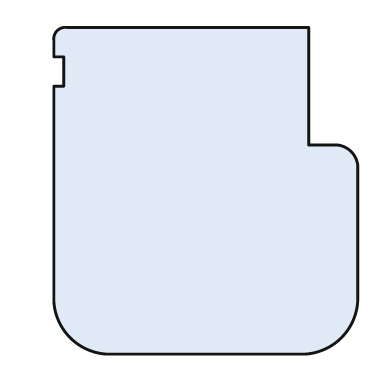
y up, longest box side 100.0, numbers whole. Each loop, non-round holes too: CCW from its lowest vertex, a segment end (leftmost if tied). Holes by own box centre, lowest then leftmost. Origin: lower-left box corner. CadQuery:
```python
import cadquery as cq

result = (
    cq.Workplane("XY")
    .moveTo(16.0, 0.0)
    .lineTo(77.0, 0.0)
    .threePointArc((88.0, 5.0), (93.0, 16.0))
    .lineTo(93.0, 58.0)
    .threePointArc((91.0, 62.0), (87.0, 64.0))
    .lineTo(78.0, 64.0)
    .lineTo(78.0, 100.0)
    .lineTo(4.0, 100.0)
    .threePointArc((1.0, 99.0), (0.0, 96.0))
    .lineTo(0.0, 91.0)
    .lineTo(3.0, 91.0)
    .lineTo(3.0, 82.0)
    .lineTo(0.0, 82.0)
    .lineTo(0.0, 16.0)
    .threePointArc((5.0, 5.0), (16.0, 0.0))
    .close()
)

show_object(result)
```